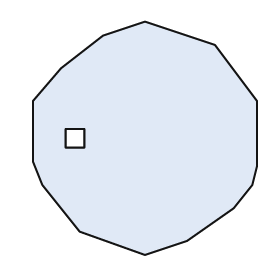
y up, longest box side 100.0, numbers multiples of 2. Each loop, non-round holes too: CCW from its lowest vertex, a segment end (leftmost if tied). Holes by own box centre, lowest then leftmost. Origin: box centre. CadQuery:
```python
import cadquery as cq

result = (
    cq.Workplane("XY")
    .moveTo(0.0, -50.0)
    .lineTo(18.0, -44.0)
    .lineTo(38.0, -30.0)
    .lineTo(46.0, -20.0)
    .lineTo(48.0, -12.0)
    .lineTo(48.0, 16.0)
    .lineTo(30.0, 40.0)
    .lineTo(0.0, 50.0)
    .lineTo(-18.0, 44.0)
    .lineTo(-36.0, 30.0)
    .lineTo(-48.0, 16.0)
    .lineTo(-48.0, -10.0)
    .lineTo(-44.0, -20.0)
    .lineTo(-28.0, -40.0)
    .close()
    .moveTo(-34.0, -4.0)
    .lineTo(-26.0, -4.0)
    .lineTo(-26.0, 4.0)
    .lineTo(-34.0, 4.0)
    .close()
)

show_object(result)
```